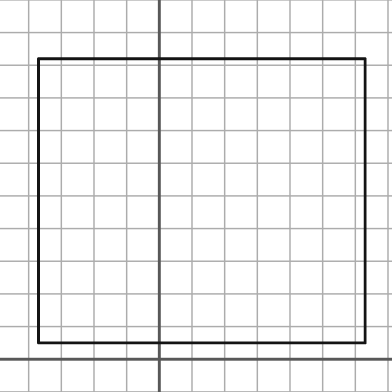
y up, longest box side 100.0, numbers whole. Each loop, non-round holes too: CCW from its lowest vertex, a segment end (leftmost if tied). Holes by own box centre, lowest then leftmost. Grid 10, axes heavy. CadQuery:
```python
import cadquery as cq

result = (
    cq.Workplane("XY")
    .moveTo(-37.0, 5.0)
    .lineTo(63.0, 5.0)
    .lineTo(63.0, 92.0)
    .lineTo(-37.0, 92.0)
    .close()
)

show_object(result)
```